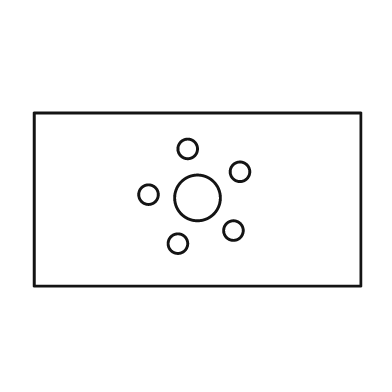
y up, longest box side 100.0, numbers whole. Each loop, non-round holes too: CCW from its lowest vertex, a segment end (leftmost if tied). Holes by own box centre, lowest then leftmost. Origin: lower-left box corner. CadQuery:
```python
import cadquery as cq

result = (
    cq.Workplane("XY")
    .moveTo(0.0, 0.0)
    .lineTo(100.0, 0.0)
    .lineTo(100.0, 53.0)
    .lineTo(0.0, 53.0)
    .close()
    .moveTo(44.0, 13.0)
    .circle(3.0)
    .moveTo(61.0, 17.0)
    .circle(3.0)
    .moveTo(50.0, 27.0)
    .circle(7.0)
    .moveTo(35.0, 28.0)
    .circle(3.0)
    .moveTo(63.0, 35.0)
    .circle(3.0)
    .moveTo(47.0, 42.0)
    .circle(3.0)
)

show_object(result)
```